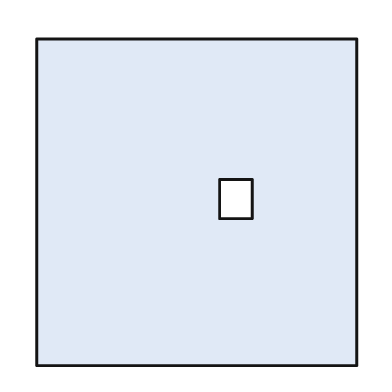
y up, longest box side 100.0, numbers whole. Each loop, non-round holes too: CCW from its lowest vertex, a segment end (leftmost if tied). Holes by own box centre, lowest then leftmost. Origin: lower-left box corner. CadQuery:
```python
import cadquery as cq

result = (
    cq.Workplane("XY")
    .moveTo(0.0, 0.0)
    .lineTo(98.0, 0.0)
    .lineTo(98.0, 100.0)
    .lineTo(0.0, 100.0)
    .close()
    .moveTo(56.0, 45.0)
    .lineTo(66.0, 45.0)
    .lineTo(66.0, 57.0)
    .lineTo(56.0, 57.0)
    .close()
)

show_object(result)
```